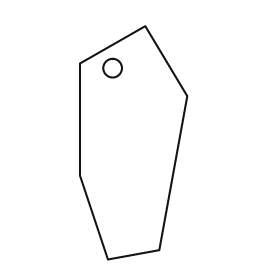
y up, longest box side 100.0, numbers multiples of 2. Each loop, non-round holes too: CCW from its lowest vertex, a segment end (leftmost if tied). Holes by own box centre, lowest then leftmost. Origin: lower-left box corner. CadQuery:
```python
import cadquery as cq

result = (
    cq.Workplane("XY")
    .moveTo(12.0, 0.0)
    .lineTo(34.0, 4.0)
    .lineTo(46.0, 70.0)
    .lineTo(28.0, 100.0)
    .lineTo(0.0, 84.0)
    .lineTo(0.0, 36.0)
    .close()
    .moveTo(14.0, 82.0)
    .circle(4.0)
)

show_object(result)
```